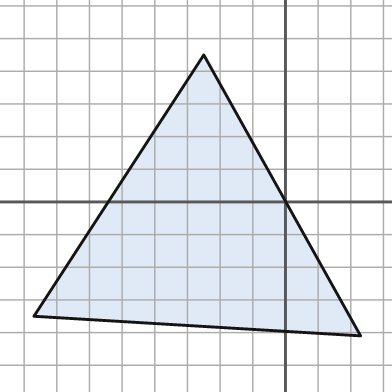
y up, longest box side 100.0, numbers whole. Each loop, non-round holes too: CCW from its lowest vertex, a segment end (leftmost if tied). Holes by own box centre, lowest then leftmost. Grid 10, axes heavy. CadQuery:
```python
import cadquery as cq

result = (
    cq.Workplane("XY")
    .moveTo(23.0, -41.0)
    .lineTo(-25.0, 45.0)
    .lineTo(-77.0, -35.0)
    .close()
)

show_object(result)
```